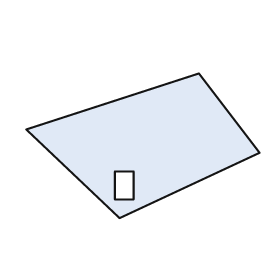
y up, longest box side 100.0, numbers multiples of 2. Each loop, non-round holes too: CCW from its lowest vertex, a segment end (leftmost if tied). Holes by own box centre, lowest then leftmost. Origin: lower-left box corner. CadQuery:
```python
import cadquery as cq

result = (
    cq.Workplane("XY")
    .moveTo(40.0, 0.0)
    .lineTo(100.0, 28.0)
    .lineTo(74.0, 62.0)
    .lineTo(0.0, 38.0)
    .close()
    .moveTo(38.0, 8.0)
    .lineTo(46.0, 8.0)
    .lineTo(46.0, 20.0)
    .lineTo(38.0, 20.0)
    .close()
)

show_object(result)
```